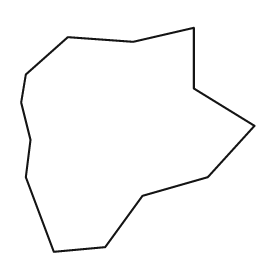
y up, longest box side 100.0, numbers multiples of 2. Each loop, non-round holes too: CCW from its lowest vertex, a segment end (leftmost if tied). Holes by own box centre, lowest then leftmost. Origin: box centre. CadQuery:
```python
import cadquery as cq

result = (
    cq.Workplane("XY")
    .moveTo(-36.0, -48.0)
    .lineTo(-14.0, -46.0)
    .lineTo(2.0, -24.0)
    .lineTo(30.0, -16.0)
    .lineTo(50.0, 6.0)
    .lineTo(24.0, 22.0)
    .lineTo(24.0, 48.0)
    .lineTo(-2.0, 42.0)
    .lineTo(-30.0, 44.0)
    .lineTo(-48.0, 28.0)
    .lineTo(-50.0, 16.0)
    .lineTo(-46.0, 0.0)
    .lineTo(-48.0, -16.0)
    .close()
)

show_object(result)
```